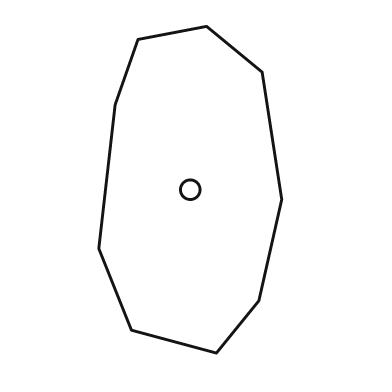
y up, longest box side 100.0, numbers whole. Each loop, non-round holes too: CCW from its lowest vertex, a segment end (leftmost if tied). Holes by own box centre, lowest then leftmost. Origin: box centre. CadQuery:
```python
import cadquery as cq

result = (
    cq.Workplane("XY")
    .moveTo(8.0, -50.0)
    .lineTo(21.0, -34.0)
    .lineTo(28.0, -3.0)
    .lineTo(22.0, 36.0)
    .lineTo(5.0, 50.0)
    .lineTo(-16.0, 46.0)
    .lineTo(-23.0, 26.0)
    .lineTo(-28.0, -18.0)
    .lineTo(-18.0, -43.0)
    .close()
    .moveTo(0.0, 0.0)
    .circle(3.0)
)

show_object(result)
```